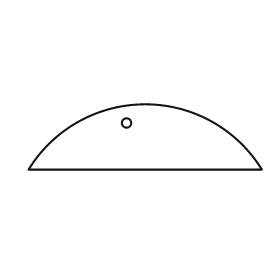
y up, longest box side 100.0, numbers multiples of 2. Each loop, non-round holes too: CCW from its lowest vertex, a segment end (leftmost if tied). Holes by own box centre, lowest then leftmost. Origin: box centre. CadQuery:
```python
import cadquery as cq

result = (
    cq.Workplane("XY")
    .moveTo(-50.0, -14.0)
    .lineTo(50.0, -14.0)
    .threePointArc((0.0, 14.0), (-50.0, -14.0))
    .close()
    .moveTo(-8.0, 6.0)
    .circle(2.0)
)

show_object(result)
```